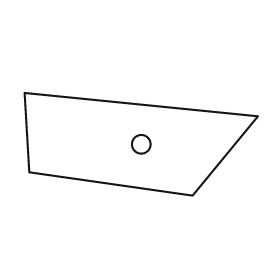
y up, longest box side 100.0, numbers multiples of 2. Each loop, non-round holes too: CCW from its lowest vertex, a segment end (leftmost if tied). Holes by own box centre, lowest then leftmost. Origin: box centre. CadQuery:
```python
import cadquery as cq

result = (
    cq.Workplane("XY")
    .moveTo(22.0, -22.0)
    .lineTo(50.0, 12.0)
    .lineTo(-50.0, 22.0)
    .lineTo(-48.0, -12.0)
    .close()
    .moveTo(0.0, 0.0)
    .circle(4.0)
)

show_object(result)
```